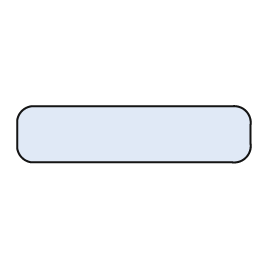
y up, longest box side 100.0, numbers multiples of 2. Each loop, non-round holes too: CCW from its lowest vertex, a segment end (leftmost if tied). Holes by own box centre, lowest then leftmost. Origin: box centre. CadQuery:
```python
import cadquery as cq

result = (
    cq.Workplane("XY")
    .moveTo(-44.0, -12.0)
    .lineTo(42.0, -12.0)
    .threePointArc((48.0, -10.0), (50.0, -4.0))
    .lineTo(50.0, 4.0)
    .threePointArc((48.0, 10.0), (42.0, 12.0))
    .lineTo(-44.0, 12.0)
    .threePointArc((-48.0, 10.0), (-50.0, 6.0))
    .lineTo(-50.0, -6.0)
    .threePointArc((-48.0, -10.0), (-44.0, -12.0))
    .close()
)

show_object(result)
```